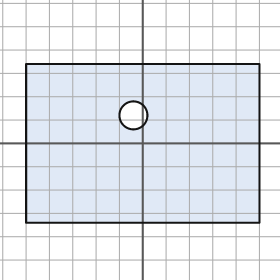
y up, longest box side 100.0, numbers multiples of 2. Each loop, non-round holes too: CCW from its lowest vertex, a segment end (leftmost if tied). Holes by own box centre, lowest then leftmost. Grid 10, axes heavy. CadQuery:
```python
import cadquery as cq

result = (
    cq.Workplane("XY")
    .moveTo(-50.0, -34.0)
    .lineTo(50.0, -34.0)
    .lineTo(50.0, 34.0)
    .lineTo(-50.0, 34.0)
    .close()
    .moveTo(-4.0, 12.0)
    .circle(6.0)
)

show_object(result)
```